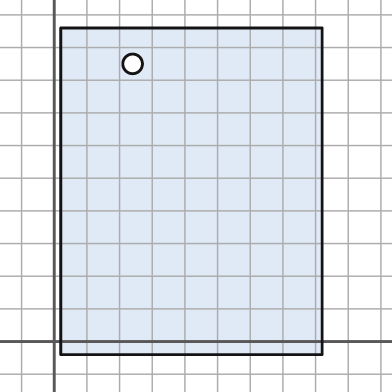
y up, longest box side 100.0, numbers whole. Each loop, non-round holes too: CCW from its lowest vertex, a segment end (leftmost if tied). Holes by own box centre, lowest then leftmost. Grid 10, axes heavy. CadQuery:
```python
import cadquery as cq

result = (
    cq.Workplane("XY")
    .moveTo(2.0, -4.0)
    .lineTo(82.0, -4.0)
    .lineTo(82.0, 96.0)
    .lineTo(2.0, 96.0)
    .close()
    .moveTo(24.0, 85.0)
    .circle(3.0)
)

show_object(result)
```